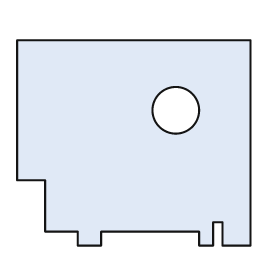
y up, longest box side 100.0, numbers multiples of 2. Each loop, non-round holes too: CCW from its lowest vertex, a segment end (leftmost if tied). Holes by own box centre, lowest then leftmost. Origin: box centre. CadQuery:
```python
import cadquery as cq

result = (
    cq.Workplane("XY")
    .moveTo(-24.0, -44.0)
    .lineTo(-14.0, -44.0)
    .lineTo(-14.0, -38.0)
    .lineTo(28.0, -38.0)
    .lineTo(28.0, -44.0)
    .lineTo(34.0, -44.0)
    .lineTo(34.0, -34.0)
    .lineTo(38.0, -34.0)
    .lineTo(38.0, -44.0)
    .lineTo(50.0, -44.0)
    .lineTo(50.0, 44.0)
    .lineTo(-50.0, 44.0)
    .lineTo(-50.0, -16.0)
    .lineTo(-38.0, -16.0)
    .lineTo(-38.0, -38.0)
    .lineTo(-24.0, -38.0)
    .close()
    .moveTo(18.0, 14.0)
    .circle(10.0)
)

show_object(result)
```